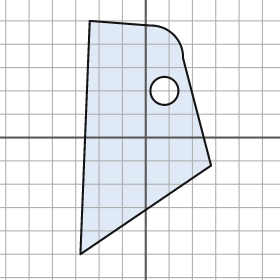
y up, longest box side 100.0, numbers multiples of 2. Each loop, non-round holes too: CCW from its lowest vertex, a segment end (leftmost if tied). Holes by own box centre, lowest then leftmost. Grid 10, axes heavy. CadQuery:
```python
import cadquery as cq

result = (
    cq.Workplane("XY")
    .moveTo(-28.0, -50.0)
    .lineTo(28.0, -12.0)
    .lineTo(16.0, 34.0)
    .threePointArc((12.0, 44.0), (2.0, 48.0))
    .lineTo(-24.0, 50.0)
    .close()
    .moveTo(8.0, 20.0)
    .circle(6.0)
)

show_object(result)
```